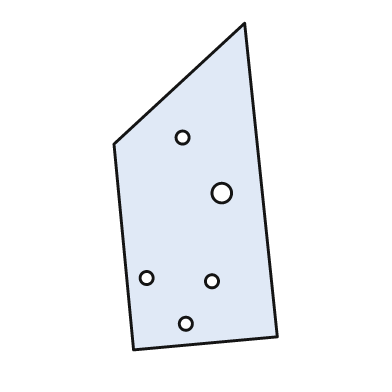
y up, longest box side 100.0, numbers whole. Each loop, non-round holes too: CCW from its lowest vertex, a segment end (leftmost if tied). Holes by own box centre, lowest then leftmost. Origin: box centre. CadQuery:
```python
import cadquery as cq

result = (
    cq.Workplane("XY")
    .moveTo(-19.0, -50.0)
    .lineTo(25.0, -46.0)
    .lineTo(15.0, 50.0)
    .lineTo(-25.0, 13.0)
    .close()
    .moveTo(-3.0, -42.0)
    .circle(2.0)
    .moveTo(5.0, -29.0)
    .circle(2.0)
    .moveTo(-15.0, -28.0)
    .circle(2.0)
    .moveTo(8.0, -2.0)
    .circle(3.0)
    .moveTo(-4.0, 15.0)
    .circle(2.0)
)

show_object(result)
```